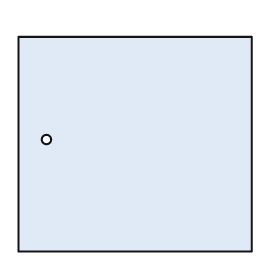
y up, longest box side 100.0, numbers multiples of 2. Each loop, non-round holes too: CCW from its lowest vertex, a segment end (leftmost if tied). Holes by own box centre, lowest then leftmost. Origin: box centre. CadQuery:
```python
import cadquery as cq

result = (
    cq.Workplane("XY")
    .moveTo(-50.0, -46.0)
    .lineTo(50.0, -46.0)
    .lineTo(50.0, 46.0)
    .lineTo(-50.0, 46.0)
    .close()
    .moveTo(-38.0, 2.0)
    .circle(2.0)
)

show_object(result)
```